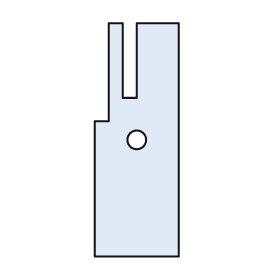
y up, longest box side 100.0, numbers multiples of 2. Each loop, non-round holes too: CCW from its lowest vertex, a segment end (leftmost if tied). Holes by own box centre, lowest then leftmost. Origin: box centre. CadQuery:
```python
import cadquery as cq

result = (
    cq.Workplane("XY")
    .moveTo(-18.0, -50.0)
    .lineTo(18.0, -50.0)
    .lineTo(18.0, 50.0)
    .lineTo(0.0, 50.0)
    .lineTo(0.0, 18.0)
    .lineTo(-6.0, 18.0)
    .lineTo(-6.0, 50.0)
    .lineTo(-12.0, 50.0)
    .lineTo(-12.0, 8.0)
    .lineTo(-18.0, 8.0)
    .close()
    .moveTo(0.0, 0.0)
    .circle(4.0)
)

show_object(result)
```